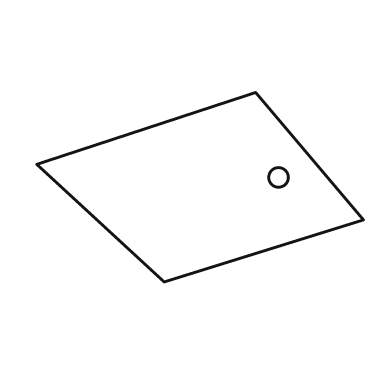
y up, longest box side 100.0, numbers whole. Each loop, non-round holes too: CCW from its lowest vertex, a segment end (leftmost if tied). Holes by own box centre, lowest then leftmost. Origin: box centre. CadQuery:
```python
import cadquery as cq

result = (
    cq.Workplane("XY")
    .moveTo(-11.0, -29.0)
    .lineTo(50.0, -10.0)
    .lineTo(17.0, 29.0)
    .lineTo(-50.0, 7.0)
    .close()
    .moveTo(24.0, 3.0)
    .circle(3.0)
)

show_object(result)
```